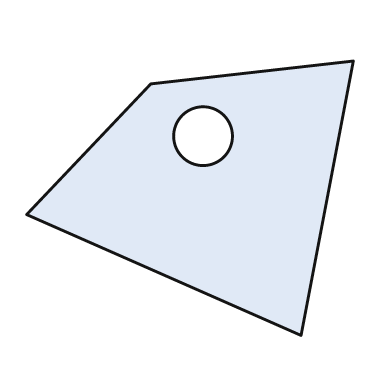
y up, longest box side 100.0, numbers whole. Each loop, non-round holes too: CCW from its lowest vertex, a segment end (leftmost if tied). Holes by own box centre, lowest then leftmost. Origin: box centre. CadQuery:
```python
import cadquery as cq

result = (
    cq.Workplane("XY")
    .moveTo(34.0, -42.0)
    .lineTo(50.0, 42.0)
    .lineTo(-12.0, 35.0)
    .lineTo(-50.0, -5.0)
    .close()
    .moveTo(4.0, 19.0)
    .circle(9.0)
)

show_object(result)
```